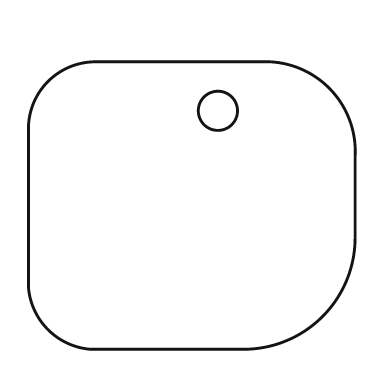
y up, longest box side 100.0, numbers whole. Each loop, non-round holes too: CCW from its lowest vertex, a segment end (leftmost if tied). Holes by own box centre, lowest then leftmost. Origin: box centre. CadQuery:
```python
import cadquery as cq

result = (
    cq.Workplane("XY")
    .moveTo(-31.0, -44.0)
    .lineTo(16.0, -44.0)
    .threePointArc((40.0, -34.0), (50.0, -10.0))
    .lineTo(50.0, 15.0)
    .threePointArc((42.0, 36.0), (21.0, 44.0))
    .lineTo(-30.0, 44.0)
    .threePointArc((-44.0, 38.0), (-50.0, 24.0))
    .lineTo(-50.0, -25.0)
    .threePointArc((-44.0, -38.0), (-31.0, -44.0))
    .close()
    .moveTo(8.0, 29.0)
    .circle(6.0)
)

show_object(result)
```